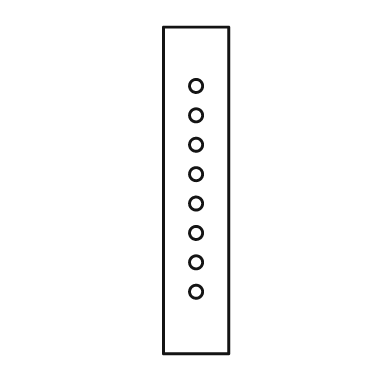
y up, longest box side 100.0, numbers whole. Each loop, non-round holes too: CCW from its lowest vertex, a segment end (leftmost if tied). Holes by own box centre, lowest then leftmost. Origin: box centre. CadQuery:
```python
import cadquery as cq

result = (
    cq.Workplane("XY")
    .moveTo(-10.0, -50.0)
    .lineTo(10.0, -50.0)
    .lineTo(10.0, 50.0)
    .lineTo(-10.0, 50.0)
    .close()
    .moveTo(0.0, -31.0)
    .circle(2.0)
    .moveTo(0.0, -22.0)
    .circle(2.0)
    .moveTo(0.0, -13.0)
    .circle(2.0)
    .moveTo(0.0, -4.0)
    .circle(2.0)
    .moveTo(0.0, 5.0)
    .circle(2.0)
    .moveTo(0.0, 14.0)
    .circle(2.0)
    .moveTo(0.0, 23.0)
    .circle(2.0)
    .moveTo(0.0, 32.0)
    .circle(2.0)
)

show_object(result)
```